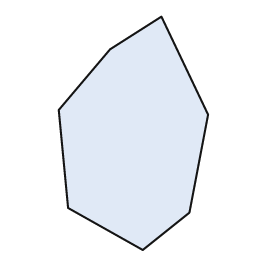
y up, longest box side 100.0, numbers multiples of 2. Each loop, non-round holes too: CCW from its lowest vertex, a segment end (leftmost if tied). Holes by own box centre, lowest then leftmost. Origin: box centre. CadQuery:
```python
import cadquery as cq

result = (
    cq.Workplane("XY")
    .moveTo(4.0, -50.0)
    .lineTo(24.0, -34.0)
    .lineTo(32.0, 8.0)
    .lineTo(12.0, 50.0)
    .lineTo(-10.0, 36.0)
    .lineTo(-32.0, 10.0)
    .lineTo(-28.0, -32.0)
    .close()
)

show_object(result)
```